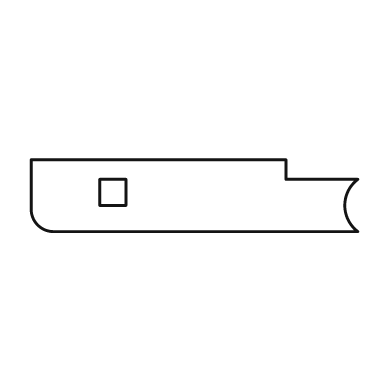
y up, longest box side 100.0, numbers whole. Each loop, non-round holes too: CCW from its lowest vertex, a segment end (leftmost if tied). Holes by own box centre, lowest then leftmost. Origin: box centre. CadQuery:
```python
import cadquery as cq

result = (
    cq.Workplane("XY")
    .moveTo(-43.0, -11.0)
    .lineTo(50.0, -11.0)
    .threePointArc((46.0, -3.0), (50.0, 5.0))
    .lineTo(28.0, 5.0)
    .lineTo(28.0, 11.0)
    .lineTo(-50.0, 11.0)
    .lineTo(-50.0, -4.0)
    .threePointArc((-48.0, -9.0), (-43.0, -11.0))
    .close()
    .moveTo(-29.0, -3.0)
    .lineTo(-21.0, -3.0)
    .lineTo(-21.0, 5.0)
    .lineTo(-29.0, 5.0)
    .close()
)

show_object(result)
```